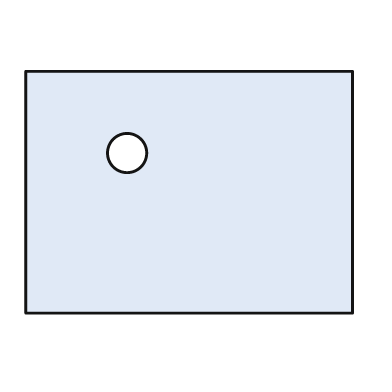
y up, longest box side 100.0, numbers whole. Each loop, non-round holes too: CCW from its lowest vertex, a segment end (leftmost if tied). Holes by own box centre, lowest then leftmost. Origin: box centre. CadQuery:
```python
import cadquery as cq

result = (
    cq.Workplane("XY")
    .moveTo(-50.0, -37.0)
    .lineTo(50.0, -37.0)
    .lineTo(50.0, 37.0)
    .lineTo(-50.0, 37.0)
    .close()
    .moveTo(-19.0, 12.0)
    .circle(6.0)
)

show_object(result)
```